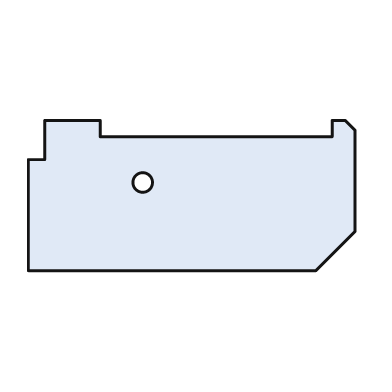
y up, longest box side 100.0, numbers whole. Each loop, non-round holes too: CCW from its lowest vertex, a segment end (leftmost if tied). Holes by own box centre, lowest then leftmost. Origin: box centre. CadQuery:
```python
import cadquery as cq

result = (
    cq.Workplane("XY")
    .moveTo(-50.0, -23.0)
    .lineTo(38.0, -23.0)
    .lineTo(50.0, -11.0)
    .lineTo(50.0, 20.0)
    .lineTo(47.0, 23.0)
    .lineTo(43.0, 23.0)
    .lineTo(43.0, 18.0)
    .lineTo(-28.0, 18.0)
    .lineTo(-28.0, 23.0)
    .lineTo(-45.0, 23.0)
    .lineTo(-45.0, 11.0)
    .lineTo(-50.0, 11.0)
    .close()
    .moveTo(-15.0, 4.0)
    .circle(3.0)
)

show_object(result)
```